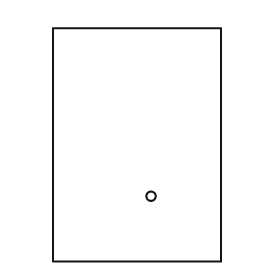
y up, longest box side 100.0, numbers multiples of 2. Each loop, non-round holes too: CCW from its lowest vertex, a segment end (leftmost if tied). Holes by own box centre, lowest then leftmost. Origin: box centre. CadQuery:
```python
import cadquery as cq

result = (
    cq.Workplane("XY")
    .moveTo(-36.0, -50.0)
    .lineTo(36.0, -50.0)
    .lineTo(36.0, 50.0)
    .lineTo(-36.0, 50.0)
    .close()
    .moveTo(6.0, -22.0)
    .circle(2.0)
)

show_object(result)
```